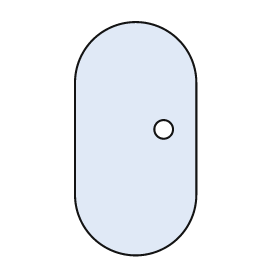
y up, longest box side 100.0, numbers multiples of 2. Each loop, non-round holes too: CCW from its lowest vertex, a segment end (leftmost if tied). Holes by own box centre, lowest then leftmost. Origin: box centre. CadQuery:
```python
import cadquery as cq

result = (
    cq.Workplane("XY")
    .moveTo(-26.0, -24.0)
    .threePointArc((0.0, -50.0), (26.0, -24.0))
    .lineTo(26.0, 24.0)
    .threePointArc((0.0, 50.0), (-26.0, 24.0))
    .close()
    .moveTo(12.0, 4.0)
    .circle(4.0)
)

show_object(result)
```